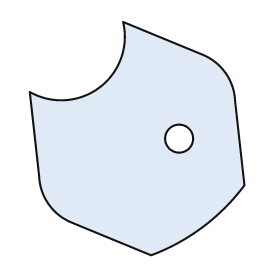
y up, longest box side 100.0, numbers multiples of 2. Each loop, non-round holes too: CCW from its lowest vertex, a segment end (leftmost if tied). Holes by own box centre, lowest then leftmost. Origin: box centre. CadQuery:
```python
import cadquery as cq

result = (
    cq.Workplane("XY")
    .moveTo(6.0, -50.0)
    .threePointArc((28.0, -38.0), (46.0, -20.0))
    .lineTo(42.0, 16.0)
    .threePointArc((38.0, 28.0), (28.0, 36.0))
    .lineTo(-6.0, 50.0)
    .threePointArc((-16.0, 22.0), (-46.0, 20.0))
    .lineTo(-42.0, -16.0)
    .threePointArc((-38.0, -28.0), (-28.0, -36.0))
    .close()
    .moveTo(18.0, 0.0)
    .circle(6.0)
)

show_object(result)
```